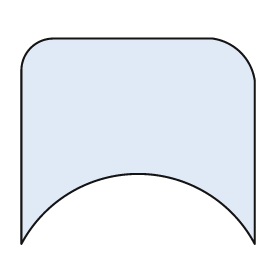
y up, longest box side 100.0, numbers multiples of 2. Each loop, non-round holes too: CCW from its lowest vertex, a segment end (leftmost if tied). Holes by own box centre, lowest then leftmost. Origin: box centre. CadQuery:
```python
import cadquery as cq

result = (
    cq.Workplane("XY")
    .moveTo(-50.0, -44.0)
    .threePointArc((0.0, -14.0), (50.0, -44.0))
    .lineTo(50.0, 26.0)
    .threePointArc((44.0, 38.0), (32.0, 44.0))
    .lineTo(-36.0, 44.0)
    .threePointArc((-46.0, 40.0), (-50.0, 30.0))
    .close()
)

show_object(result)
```